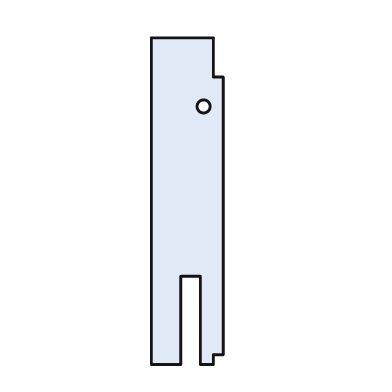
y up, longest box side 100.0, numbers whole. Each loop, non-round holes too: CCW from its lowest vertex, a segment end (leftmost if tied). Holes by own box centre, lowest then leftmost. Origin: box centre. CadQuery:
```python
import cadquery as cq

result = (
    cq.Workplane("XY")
    .moveTo(-11.0, -50.0)
    .lineTo(-2.0, -50.0)
    .lineTo(-2.0, -23.0)
    .lineTo(4.0, -23.0)
    .lineTo(4.0, -50.0)
    .lineTo(8.0, -50.0)
    .lineTo(8.0, -47.0)
    .lineTo(11.0, -47.0)
    .lineTo(11.0, 38.0)
    .lineTo(8.0, 38.0)
    .lineTo(8.0, 50.0)
    .lineTo(-11.0, 50.0)
    .close()
    .moveTo(5.0, 29.0)
    .circle(2.0)
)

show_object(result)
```